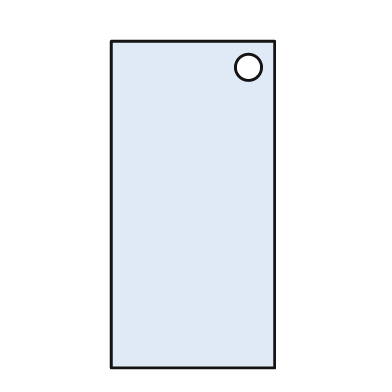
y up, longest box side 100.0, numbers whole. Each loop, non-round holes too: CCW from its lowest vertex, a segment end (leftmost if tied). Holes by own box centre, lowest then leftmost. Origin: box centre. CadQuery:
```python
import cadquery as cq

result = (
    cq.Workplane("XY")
    .moveTo(-25.0, -50.0)
    .lineTo(25.0, -50.0)
    .lineTo(25.0, 50.0)
    .lineTo(-25.0, 50.0)
    .close()
    .moveTo(17.0, 42.0)
    .circle(4.0)
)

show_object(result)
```